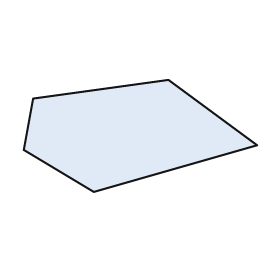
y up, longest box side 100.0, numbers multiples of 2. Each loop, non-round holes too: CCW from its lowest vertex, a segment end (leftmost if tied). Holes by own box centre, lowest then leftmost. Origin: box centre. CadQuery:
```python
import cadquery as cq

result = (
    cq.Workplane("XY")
    .moveTo(-20.0, -24.0)
    .lineTo(50.0, -4.0)
    .lineTo(12.0, 24.0)
    .lineTo(-46.0, 16.0)
    .lineTo(-50.0, -6.0)
    .close()
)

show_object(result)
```